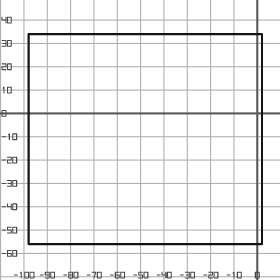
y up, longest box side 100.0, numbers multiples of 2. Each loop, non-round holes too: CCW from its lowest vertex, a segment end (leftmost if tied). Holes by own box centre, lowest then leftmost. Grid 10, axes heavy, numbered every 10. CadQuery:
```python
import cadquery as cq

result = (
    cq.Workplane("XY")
    .moveTo(-98.0, -56.0)
    .lineTo(2.0, -56.0)
    .lineTo(2.0, 34.0)
    .lineTo(-98.0, 34.0)
    .close()
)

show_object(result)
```